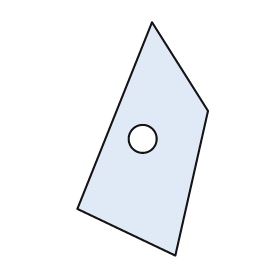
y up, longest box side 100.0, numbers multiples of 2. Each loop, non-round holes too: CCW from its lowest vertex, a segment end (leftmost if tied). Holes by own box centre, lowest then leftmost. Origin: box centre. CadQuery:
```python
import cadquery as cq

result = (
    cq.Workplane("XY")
    .moveTo(14.0, -50.0)
    .lineTo(28.0, 12.0)
    .lineTo(4.0, 50.0)
    .lineTo(-28.0, -30.0)
    .close()
    .moveTo(0.0, 0.0)
    .circle(6.0)
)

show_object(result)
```